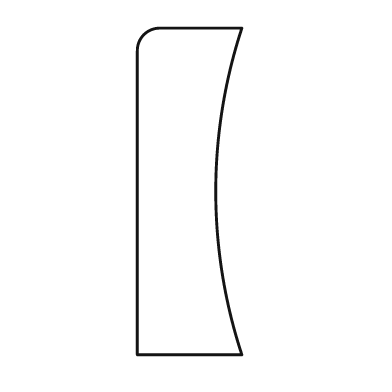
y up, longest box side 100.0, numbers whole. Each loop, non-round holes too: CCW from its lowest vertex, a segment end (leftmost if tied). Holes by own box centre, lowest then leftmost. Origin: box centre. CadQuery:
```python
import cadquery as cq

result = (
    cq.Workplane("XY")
    .moveTo(-16.0, -50.0)
    .lineTo(16.0, -50.0)
    .threePointArc((8.0, 0.0), (16.0, 50.0))
    .lineTo(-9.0, 50.0)
    .threePointArc((-14.0, 48.0), (-16.0, 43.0))
    .close()
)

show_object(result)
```